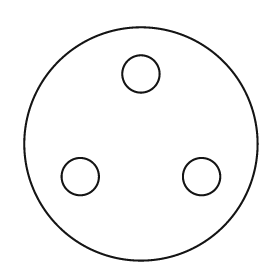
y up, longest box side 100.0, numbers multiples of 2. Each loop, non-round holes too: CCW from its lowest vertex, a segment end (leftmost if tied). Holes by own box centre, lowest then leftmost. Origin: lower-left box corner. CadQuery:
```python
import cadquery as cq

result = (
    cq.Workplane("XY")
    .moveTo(50.0, 50.0)
    .circle(50.0)
    .moveTo(24.0, 36.0)
    .circle(8.0)
    .moveTo(76.0, 36.0)
    .circle(8.0)
    .moveTo(50.0, 80.0)
    .circle(8.0)
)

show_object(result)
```